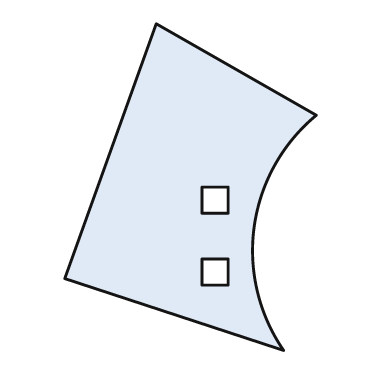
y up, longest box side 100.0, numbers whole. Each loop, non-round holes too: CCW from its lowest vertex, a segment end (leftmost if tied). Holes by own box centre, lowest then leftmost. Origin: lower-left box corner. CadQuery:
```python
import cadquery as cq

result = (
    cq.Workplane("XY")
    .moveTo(67.0, 0.0)
    .threePointArc((58.0, 38.0), (77.0, 72.0))
    .lineTo(28.0, 100.0)
    .lineTo(0.0, 22.0)
    .close()
    .moveTo(42.0, 20.0)
    .lineTo(50.0, 20.0)
    .lineTo(50.0, 28.0)
    .lineTo(42.0, 28.0)
    .close()
    .moveTo(42.0, 42.0)
    .lineTo(50.0, 42.0)
    .lineTo(50.0, 50.0)
    .lineTo(42.0, 50.0)
    .close()
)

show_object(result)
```